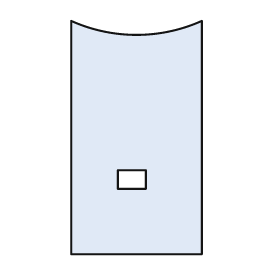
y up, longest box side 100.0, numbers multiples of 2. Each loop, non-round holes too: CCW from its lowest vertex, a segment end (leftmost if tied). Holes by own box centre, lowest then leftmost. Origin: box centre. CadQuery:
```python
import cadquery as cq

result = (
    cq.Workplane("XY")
    .moveTo(-28.0, -50.0)
    .lineTo(28.0, -50.0)
    .lineTo(28.0, 50.0)
    .threePointArc((0.0, 44.0), (-28.0, 50.0))
    .close()
    .moveTo(-8.0, -22.0)
    .lineTo(4.0, -22.0)
    .lineTo(4.0, -14.0)
    .lineTo(-8.0, -14.0)
    .close()
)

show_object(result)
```